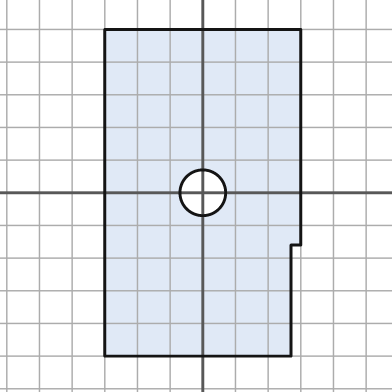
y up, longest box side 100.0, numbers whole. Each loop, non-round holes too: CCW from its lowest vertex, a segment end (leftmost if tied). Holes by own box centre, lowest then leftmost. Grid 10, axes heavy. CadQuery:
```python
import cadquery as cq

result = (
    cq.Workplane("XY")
    .moveTo(-30.0, -50.0)
    .lineTo(27.0, -50.0)
    .lineTo(27.0, -16.0)
    .lineTo(30.0, -16.0)
    .lineTo(30.0, 50.0)
    .lineTo(-30.0, 50.0)
    .close()
    .moveTo(0.0, 0.0)
    .circle(7.0)
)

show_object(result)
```